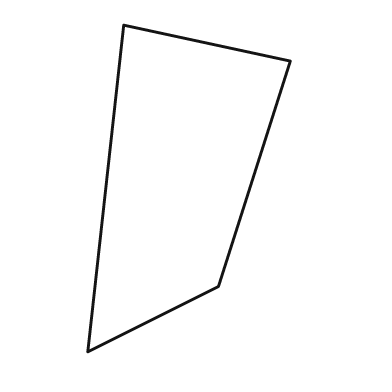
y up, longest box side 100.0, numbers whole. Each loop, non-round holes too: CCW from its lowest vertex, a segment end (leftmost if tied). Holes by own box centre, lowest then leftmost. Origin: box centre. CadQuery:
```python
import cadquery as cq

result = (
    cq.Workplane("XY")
    .moveTo(-31.0, -50.0)
    .lineTo(9.0, -30.0)
    .lineTo(31.0, 39.0)
    .lineTo(-20.0, 50.0)
    .close()
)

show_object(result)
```